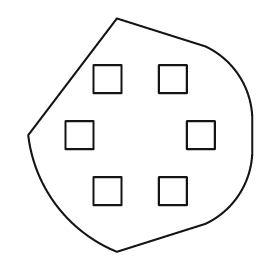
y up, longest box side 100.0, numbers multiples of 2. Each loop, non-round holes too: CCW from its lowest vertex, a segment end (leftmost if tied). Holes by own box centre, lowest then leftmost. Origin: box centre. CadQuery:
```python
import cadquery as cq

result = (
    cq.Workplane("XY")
    .moveTo(-10.0, -50.0)
    .lineTo(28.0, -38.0)
    .threePointArc((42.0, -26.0), (48.0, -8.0))
    .lineTo(48.0, 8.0)
    .threePointArc((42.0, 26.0), (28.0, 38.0))
    .lineTo(-10.0, 50.0)
    .lineTo(-48.0, 0.0)
    .threePointArc((-36.0, -30.0), (-10.0, -50.0))
    .close()
    .moveTo(-20.0, -30.0)
    .lineTo(-8.0, -30.0)
    .lineTo(-8.0, -18.0)
    .lineTo(-20.0, -18.0)
    .close()
    .moveTo(8.0, -30.0)
    .lineTo(20.0, -30.0)
    .lineTo(20.0, -18.0)
    .lineTo(8.0, -18.0)
    .close()
    .moveTo(-32.0, -6.0)
    .lineTo(-20.0, -6.0)
    .lineTo(-20.0, 6.0)
    .lineTo(-32.0, 6.0)
    .close()
    .moveTo(20.0, -6.0)
    .lineTo(32.0, -6.0)
    .lineTo(32.0, 6.0)
    .lineTo(20.0, 6.0)
    .close()
    .moveTo(-20.0, 18.0)
    .lineTo(-8.0, 18.0)
    .lineTo(-8.0, 30.0)
    .lineTo(-20.0, 30.0)
    .close()
    .moveTo(8.0, 18.0)
    .lineTo(20.0, 18.0)
    .lineTo(20.0, 30.0)
    .lineTo(8.0, 30.0)
    .close()
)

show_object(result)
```